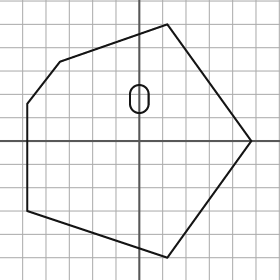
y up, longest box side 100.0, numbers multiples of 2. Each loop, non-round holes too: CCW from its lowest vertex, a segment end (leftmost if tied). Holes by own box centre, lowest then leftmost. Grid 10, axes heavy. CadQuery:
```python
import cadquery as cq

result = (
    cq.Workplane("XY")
    .moveTo(12.0, -50.0)
    .lineTo(48.0, 0.0)
    .lineTo(12.0, 50.0)
    .lineTo(-34.0, 34.0)
    .lineTo(-48.0, 16.0)
    .lineTo(-48.0, -30.0)
    .close()
    .moveTo(-4.0, 16.0)
    .threePointArc((0.0, 12.0), (4.0, 16.0))
    .lineTo(4.0, 20.0)
    .threePointArc((0.0, 24.0), (-4.0, 20.0))
    .close()
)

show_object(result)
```